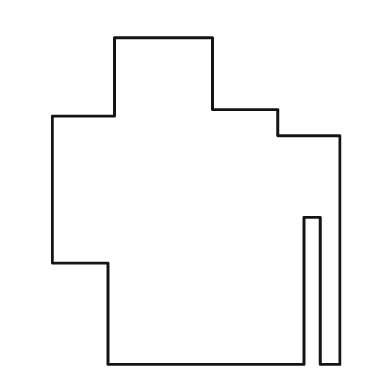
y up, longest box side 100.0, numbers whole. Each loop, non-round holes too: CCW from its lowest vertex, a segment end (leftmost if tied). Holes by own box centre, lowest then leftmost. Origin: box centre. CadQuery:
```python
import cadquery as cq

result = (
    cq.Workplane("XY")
    .moveTo(-27.0, -50.0)
    .lineTo(33.0, -50.0)
    .lineTo(33.0, -5.0)
    .lineTo(38.0, -5.0)
    .lineTo(38.0, -50.0)
    .lineTo(44.0, -50.0)
    .lineTo(44.0, 20.0)
    .lineTo(25.0, 20.0)
    .lineTo(25.0, 28.0)
    .lineTo(5.0, 28.0)
    .lineTo(5.0, 50.0)
    .lineTo(-25.0, 50.0)
    .lineTo(-25.0, 26.0)
    .lineTo(-44.0, 26.0)
    .lineTo(-44.0, -19.0)
    .lineTo(-27.0, -19.0)
    .close()
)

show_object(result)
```